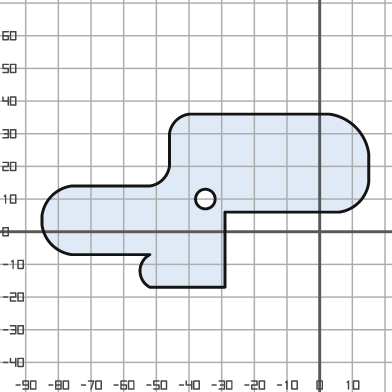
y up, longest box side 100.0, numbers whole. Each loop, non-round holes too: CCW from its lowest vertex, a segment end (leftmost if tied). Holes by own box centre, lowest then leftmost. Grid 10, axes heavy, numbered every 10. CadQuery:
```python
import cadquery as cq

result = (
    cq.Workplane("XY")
    .moveTo(-52.0, -17.0)
    .lineTo(-29.0, -17.0)
    .lineTo(-29.0, 6.0)
    .lineTo(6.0, 6.0)
    .threePointArc((12.0, 9.0), (15.0, 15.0))
    .lineTo(15.0, 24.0)
    .threePointArc((11.0, 32.0), (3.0, 36.0))
    .lineTo(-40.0, 36.0)
    .threePointArc((-44.0, 34.0), (-46.0, 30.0))
    .lineTo(-46.0, 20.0)
    .threePointArc((-48.0, 16.0), (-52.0, 14.0))
    .lineTo(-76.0, 14.0)
    .threePointArc((-82.0, 11.0), (-85.0, 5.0))
    .lineTo(-85.0, 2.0)
    .threePointArc((-82.0, -4.0), (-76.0, -7.0))
    .lineTo(-52.0, -7.0)
    .threePointArc((-55.0, -12.0), (-52.0, -17.0))
    .close()
    .moveTo(-35.0, 10.0)
    .circle(3.0)
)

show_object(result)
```